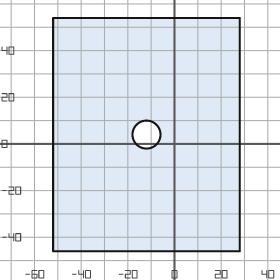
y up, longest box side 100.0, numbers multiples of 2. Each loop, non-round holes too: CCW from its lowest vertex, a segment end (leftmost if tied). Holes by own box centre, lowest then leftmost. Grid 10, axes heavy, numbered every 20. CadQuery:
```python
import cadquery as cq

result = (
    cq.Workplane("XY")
    .moveTo(-52.0, -46.0)
    .lineTo(28.0, -46.0)
    .lineTo(28.0, 54.0)
    .lineTo(-52.0, 54.0)
    .close()
    .moveTo(-12.0, 4.0)
    .circle(6.0)
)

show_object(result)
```